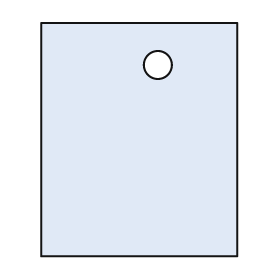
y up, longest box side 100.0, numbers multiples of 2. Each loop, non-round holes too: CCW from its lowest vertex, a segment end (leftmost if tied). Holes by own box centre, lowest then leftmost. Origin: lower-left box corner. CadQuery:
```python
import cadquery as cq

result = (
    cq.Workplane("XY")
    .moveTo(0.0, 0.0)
    .lineTo(84.0, 0.0)
    .lineTo(84.0, 100.0)
    .lineTo(0.0, 100.0)
    .close()
    .moveTo(50.0, 82.0)
    .circle(6.0)
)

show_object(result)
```